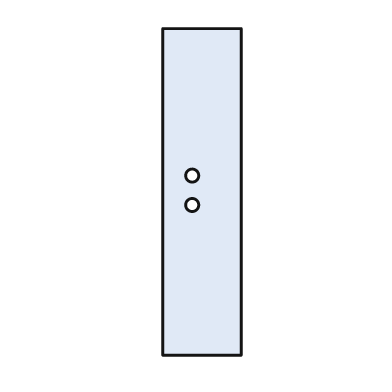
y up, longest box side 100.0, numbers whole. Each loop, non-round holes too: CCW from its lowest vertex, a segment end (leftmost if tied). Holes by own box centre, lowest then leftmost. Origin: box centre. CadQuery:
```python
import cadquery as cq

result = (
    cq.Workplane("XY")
    .moveTo(-12.0, -50.0)
    .lineTo(12.0, -50.0)
    .lineTo(12.0, 50.0)
    .lineTo(-12.0, 50.0)
    .close()
    .moveTo(-3.0, -4.0)
    .circle(2.0)
    .moveTo(-3.0, 5.0)
    .circle(2.0)
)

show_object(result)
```